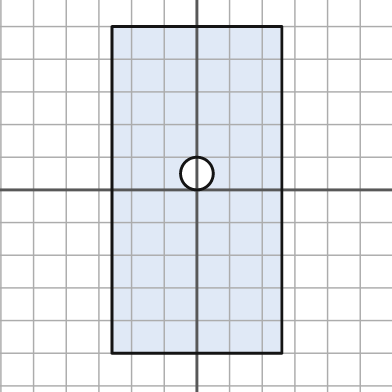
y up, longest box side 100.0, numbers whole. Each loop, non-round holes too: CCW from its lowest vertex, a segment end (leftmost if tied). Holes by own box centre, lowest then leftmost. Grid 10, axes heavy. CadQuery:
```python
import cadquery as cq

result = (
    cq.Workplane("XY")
    .moveTo(-26.0, -50.0)
    .lineTo(26.0, -50.0)
    .lineTo(26.0, 50.0)
    .lineTo(-26.0, 50.0)
    .close()
    .moveTo(0.0, 5.0)
    .circle(5.0)
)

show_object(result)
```